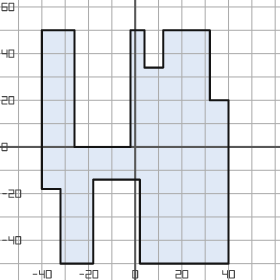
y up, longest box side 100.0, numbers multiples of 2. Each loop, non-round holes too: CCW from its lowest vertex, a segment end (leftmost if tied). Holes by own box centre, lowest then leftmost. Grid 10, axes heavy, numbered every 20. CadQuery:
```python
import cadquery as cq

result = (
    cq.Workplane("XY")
    .moveTo(-32.0, -50.0)
    .lineTo(-18.0, -50.0)
    .lineTo(-18.0, -14.0)
    .lineTo(2.0, -14.0)
    .lineTo(2.0, -50.0)
    .lineTo(40.0, -50.0)
    .lineTo(40.0, 20.0)
    .lineTo(32.0, 20.0)
    .lineTo(32.0, 50.0)
    .lineTo(12.0, 50.0)
    .lineTo(12.0, 34.0)
    .lineTo(4.0, 34.0)
    .lineTo(4.0, 50.0)
    .lineTo(-2.0, 50.0)
    .lineTo(-2.0, 0.0)
    .lineTo(-26.0, 0.0)
    .lineTo(-26.0, 50.0)
    .lineTo(-40.0, 50.0)
    .lineTo(-40.0, -18.0)
    .lineTo(-32.0, -18.0)
    .close()
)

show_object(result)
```